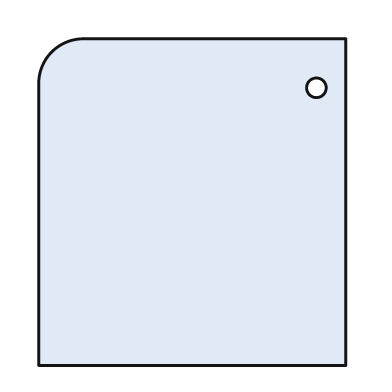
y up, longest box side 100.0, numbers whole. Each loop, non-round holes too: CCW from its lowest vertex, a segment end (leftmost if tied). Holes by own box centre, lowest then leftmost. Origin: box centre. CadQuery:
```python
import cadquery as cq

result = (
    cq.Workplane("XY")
    .moveTo(-47.0, -50.0)
    .lineTo(47.0, -50.0)
    .lineTo(47.0, 50.0)
    .lineTo(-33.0, 50.0)
    .threePointArc((-43.0, 46.0), (-47.0, 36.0))
    .close()
    .moveTo(38.0, 35.0)
    .circle(3.0)
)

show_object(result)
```